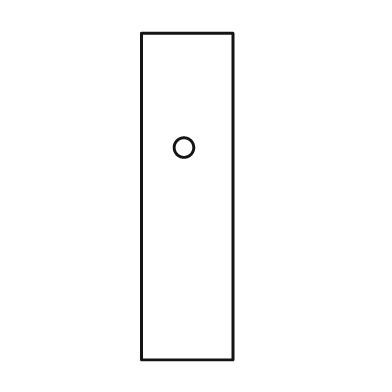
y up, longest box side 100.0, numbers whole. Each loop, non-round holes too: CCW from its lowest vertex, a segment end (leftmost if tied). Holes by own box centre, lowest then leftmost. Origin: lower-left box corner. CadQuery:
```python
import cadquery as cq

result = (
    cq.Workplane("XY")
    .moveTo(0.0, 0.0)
    .lineTo(28.0, 0.0)
    .lineTo(28.0, 100.0)
    .lineTo(0.0, 100.0)
    .close()
    .moveTo(13.0, 65.0)
    .circle(3.0)
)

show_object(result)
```